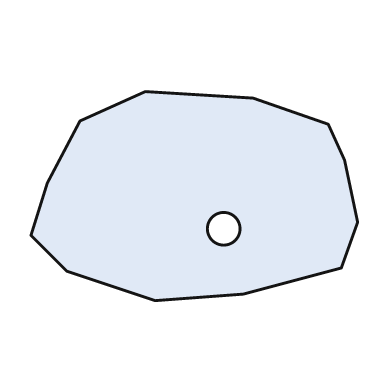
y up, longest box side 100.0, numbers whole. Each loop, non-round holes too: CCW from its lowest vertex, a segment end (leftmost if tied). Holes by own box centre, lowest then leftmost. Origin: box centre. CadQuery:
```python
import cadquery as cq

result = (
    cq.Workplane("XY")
    .moveTo(-12.0, -32.0)
    .lineTo(15.0, -30.0)
    .lineTo(45.0, -22.0)
    .lineTo(50.0, -8.0)
    .lineTo(46.0, 11.0)
    .lineTo(41.0, 22.0)
    .lineTo(18.0, 30.0)
    .lineTo(-15.0, 32.0)
    .lineTo(-35.0, 23.0)
    .lineTo(-45.0, 4.0)
    .lineTo(-50.0, -12.0)
    .lineTo(-39.0, -23.0)
    .close()
    .moveTo(9.0, -10.0)
    .circle(5.0)
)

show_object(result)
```